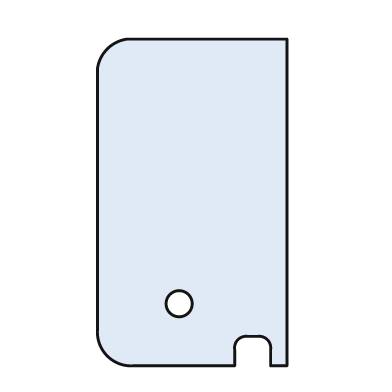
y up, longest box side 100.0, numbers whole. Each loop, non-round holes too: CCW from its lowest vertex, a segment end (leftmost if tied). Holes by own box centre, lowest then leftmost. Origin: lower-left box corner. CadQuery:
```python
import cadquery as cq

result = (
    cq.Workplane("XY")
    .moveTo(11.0, 0.0)
    .lineTo(42.0, 0.0)
    .lineTo(42.0, 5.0)
    .threePointArc((43.0, 8.0), (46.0, 9.0))
    .lineTo(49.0, 9.0)
    .threePointArc((52.0, 8.0), (53.0, 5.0))
    .lineTo(53.0, 0.0)
    .lineTo(58.0, 0.0)
    .lineTo(58.0, 100.0)
    .lineTo(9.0, 100.0)
    .threePointArc((3.0, 97.0), (0.0, 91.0))
    .lineTo(0.0, 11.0)
    .threePointArc((3.0, 3.0), (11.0, 0.0))
    .close()
    .moveTo(25.0, 19.0)
    .circle(4.0)
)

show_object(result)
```